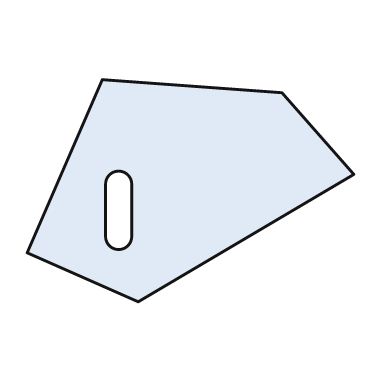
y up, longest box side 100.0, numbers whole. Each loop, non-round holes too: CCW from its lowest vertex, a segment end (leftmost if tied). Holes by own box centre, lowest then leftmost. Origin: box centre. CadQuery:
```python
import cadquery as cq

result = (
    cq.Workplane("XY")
    .moveTo(-16.0, -34.0)
    .lineTo(50.0, 5.0)
    .lineTo(28.0, 30.0)
    .lineTo(-27.0, 34.0)
    .lineTo(-50.0, -19.0)
    .close()
    .moveTo(-26.0, -14.0)
    .threePointArc((-22.0, -18.0), (-18.0, -14.0))
    .lineTo(-18.0, 2.0)
    .threePointArc((-22.0, 6.0), (-26.0, 2.0))
    .close()
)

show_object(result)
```